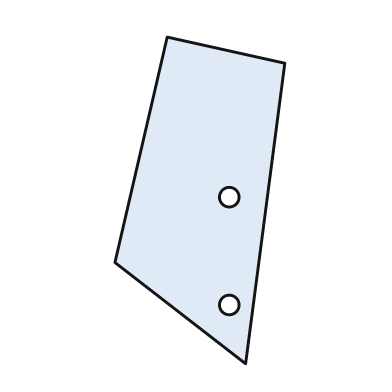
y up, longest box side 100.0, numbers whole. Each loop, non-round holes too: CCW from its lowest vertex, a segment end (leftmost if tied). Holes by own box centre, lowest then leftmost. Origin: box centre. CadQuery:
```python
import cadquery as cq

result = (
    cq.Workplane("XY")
    .moveTo(14.0, -50.0)
    .lineTo(26.0, 42.0)
    .lineTo(-10.0, 50.0)
    .lineTo(-26.0, -19.0)
    .close()
    .moveTo(9.0, -32.0)
    .circle(3.0)
    .moveTo(9.0, 1.0)
    .circle(3.0)
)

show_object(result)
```